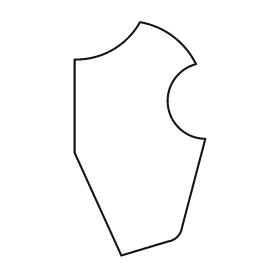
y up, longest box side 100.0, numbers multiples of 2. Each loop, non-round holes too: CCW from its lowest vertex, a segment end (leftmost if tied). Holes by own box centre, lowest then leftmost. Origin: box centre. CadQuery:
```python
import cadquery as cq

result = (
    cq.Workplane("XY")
    .moveTo(-8.0, -50.0)
    .lineTo(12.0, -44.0)
    .threePointArc((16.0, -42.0), (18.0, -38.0))
    .lineTo(28.0, 0.0)
    .threePointArc((12.0, 14.0), (24.0, 32.0))
    .threePointArc((14.0, 44.0), (0.0, 50.0))
    .threePointArc((-12.0, 38.0), (-28.0, 34.0))
    .lineTo(-28.0, -6.0)
    .close()
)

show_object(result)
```